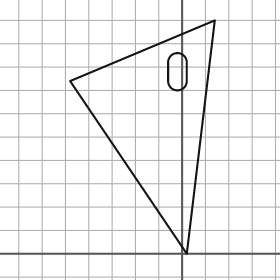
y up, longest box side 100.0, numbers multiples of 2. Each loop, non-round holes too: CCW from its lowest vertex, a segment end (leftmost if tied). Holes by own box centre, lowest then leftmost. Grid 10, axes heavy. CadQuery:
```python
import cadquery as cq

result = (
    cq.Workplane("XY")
    .moveTo(2.0, 0.0)
    .lineTo(14.0, 100.0)
    .lineTo(-48.0, 74.0)
    .close()
    .moveTo(-6.0, 74.0)
    .threePointArc((-2.0, 70.0), (2.0, 74.0))
    .lineTo(2.0, 82.0)
    .threePointArc((-2.0, 86.0), (-6.0, 82.0))
    .close()
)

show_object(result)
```